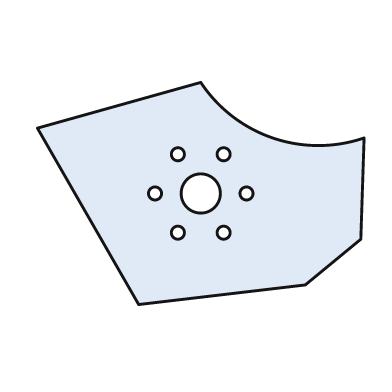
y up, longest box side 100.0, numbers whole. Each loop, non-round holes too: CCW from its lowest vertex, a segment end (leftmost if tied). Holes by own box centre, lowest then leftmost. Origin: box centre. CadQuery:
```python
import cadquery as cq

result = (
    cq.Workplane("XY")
    .moveTo(-19.0, -34.0)
    .lineTo(32.0, -28.0)
    .lineTo(49.0, -14.0)
    .lineTo(50.0, 17.0)
    .threePointArc((22.0, 17.0), (0.0, 34.0))
    .lineTo(-50.0, 20.0)
    .close()
    .moveTo(-7.0, -12.0)
    .circle(2.0)
    .moveTo(7.0, -12.0)
    .circle(2.0)
    .moveTo(-14.0, 0.0)
    .circle(2.0)
    .moveTo(0.0, 0.0)
    .circle(6.0)
    .moveTo(14.0, 0.0)
    .circle(2.0)
    .moveTo(-7.0, 12.0)
    .circle(2.0)
    .moveTo(7.0, 12.0)
    .circle(2.0)
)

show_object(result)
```